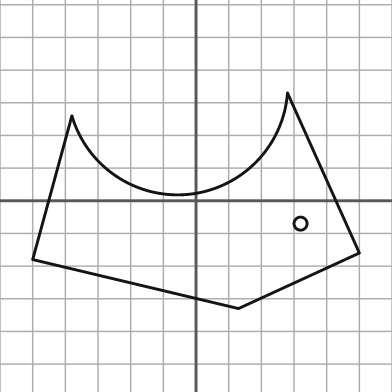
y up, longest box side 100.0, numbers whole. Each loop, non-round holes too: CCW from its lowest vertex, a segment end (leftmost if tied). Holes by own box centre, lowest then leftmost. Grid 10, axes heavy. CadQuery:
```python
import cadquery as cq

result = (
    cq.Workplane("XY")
    .moveTo(13.0, -33.0)
    .lineTo(50.0, -16.0)
    .lineTo(28.0, 33.0)
    .threePointArc((-2.0, 2.0), (-38.0, 26.0))
    .lineTo(-50.0, -18.0)
    .close()
    .moveTo(32.0, -7.0)
    .circle(2.0)
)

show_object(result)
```